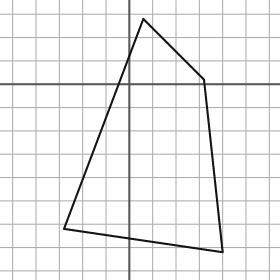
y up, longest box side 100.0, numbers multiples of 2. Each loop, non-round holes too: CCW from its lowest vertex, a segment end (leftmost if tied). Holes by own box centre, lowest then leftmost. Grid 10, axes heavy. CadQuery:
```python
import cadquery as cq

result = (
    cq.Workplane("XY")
    .moveTo(40.0, -72.0)
    .lineTo(32.0, 2.0)
    .lineTo(6.0, 28.0)
    .lineTo(-28.0, -62.0)
    .close()
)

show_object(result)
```